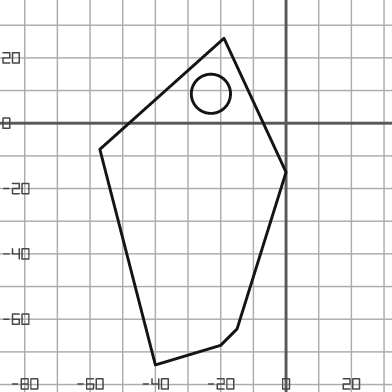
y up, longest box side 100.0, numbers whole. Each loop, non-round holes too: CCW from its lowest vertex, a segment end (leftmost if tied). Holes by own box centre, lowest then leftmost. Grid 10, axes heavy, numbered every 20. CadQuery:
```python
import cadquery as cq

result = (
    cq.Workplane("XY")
    .moveTo(-40.0, -74.0)
    .lineTo(-20.0, -68.0)
    .lineTo(-15.0, -63.0)
    .lineTo(0.0, -15.0)
    .lineTo(-19.0, 26.0)
    .lineTo(-57.0, -8.0)
    .close()
    .moveTo(-23.0, 9.0)
    .circle(6.0)
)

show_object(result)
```